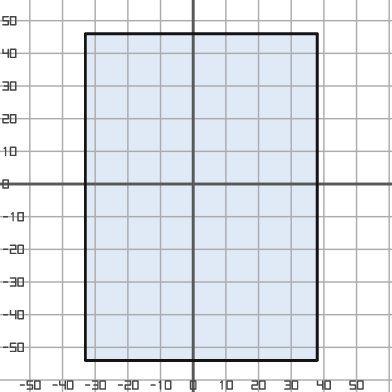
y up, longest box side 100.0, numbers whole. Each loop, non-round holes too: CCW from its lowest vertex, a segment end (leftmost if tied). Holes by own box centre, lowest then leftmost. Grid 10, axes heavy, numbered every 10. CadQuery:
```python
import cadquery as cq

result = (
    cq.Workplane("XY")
    .moveTo(-33.0, -54.0)
    .lineTo(38.0, -54.0)
    .lineTo(38.0, 46.0)
    .lineTo(-33.0, 46.0)
    .close()
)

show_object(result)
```